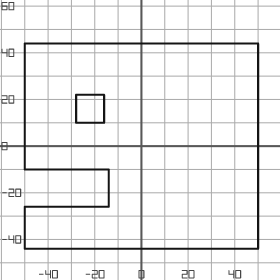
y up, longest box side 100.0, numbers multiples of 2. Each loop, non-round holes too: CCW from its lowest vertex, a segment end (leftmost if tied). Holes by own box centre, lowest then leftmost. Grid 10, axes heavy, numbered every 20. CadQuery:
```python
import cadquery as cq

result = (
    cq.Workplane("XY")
    .moveTo(-50.0, -44.0)
    .lineTo(50.0, -44.0)
    .lineTo(50.0, 44.0)
    .lineTo(-50.0, 44.0)
    .lineTo(-50.0, -10.0)
    .lineTo(-14.0, -10.0)
    .lineTo(-14.0, -26.0)
    .lineTo(-50.0, -26.0)
    .close()
    .moveTo(-28.0, 10.0)
    .lineTo(-16.0, 10.0)
    .lineTo(-16.0, 22.0)
    .lineTo(-28.0, 22.0)
    .close()
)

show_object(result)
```